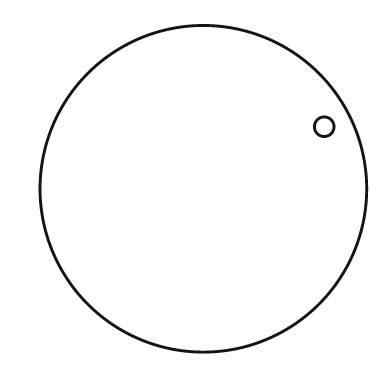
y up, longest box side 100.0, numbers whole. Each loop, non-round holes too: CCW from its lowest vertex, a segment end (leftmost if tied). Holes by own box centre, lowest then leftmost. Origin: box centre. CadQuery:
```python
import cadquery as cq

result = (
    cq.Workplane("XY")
    .moveTo(0.0, 0.0)
    .circle(50.0)
    .moveTo(37.0, 19.0)
    .circle(3.0)
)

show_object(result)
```